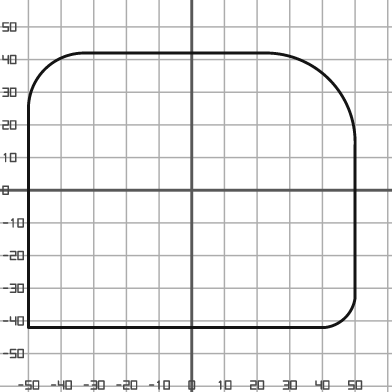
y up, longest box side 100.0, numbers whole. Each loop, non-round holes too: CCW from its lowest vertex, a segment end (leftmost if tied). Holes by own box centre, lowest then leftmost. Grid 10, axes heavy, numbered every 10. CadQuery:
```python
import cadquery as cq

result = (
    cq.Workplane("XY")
    .moveTo(-50.0, -42.0)
    .lineTo(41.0, -42.0)
    .threePointArc((47.0, -39.0), (50.0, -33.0))
    .lineTo(50.0, 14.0)
    .threePointArc((42.0, 34.0), (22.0, 42.0))
    .lineTo(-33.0, 42.0)
    .threePointArc((-45.0, 37.0), (-50.0, 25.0))
    .close()
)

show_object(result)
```